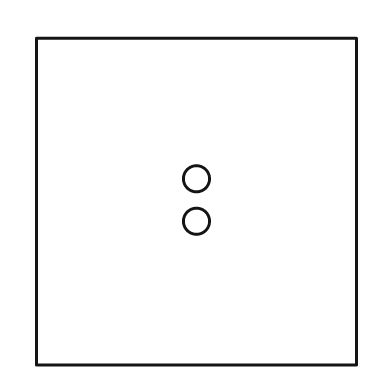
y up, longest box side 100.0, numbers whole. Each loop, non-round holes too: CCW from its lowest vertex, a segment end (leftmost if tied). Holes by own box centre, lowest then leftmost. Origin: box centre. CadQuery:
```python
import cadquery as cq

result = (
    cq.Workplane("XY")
    .moveTo(-49.0, -50.0)
    .lineTo(49.0, -50.0)
    .lineTo(49.0, 50.0)
    .lineTo(-49.0, 50.0)
    .close()
    .moveTo(0.0, -6.0)
    .circle(4.0)
    .moveTo(0.0, 7.0)
    .circle(4.0)
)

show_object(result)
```